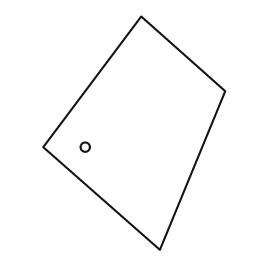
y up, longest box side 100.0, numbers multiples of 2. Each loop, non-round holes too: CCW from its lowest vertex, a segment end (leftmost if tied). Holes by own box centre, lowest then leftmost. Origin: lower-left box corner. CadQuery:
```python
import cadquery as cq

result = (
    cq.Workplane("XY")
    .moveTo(50.0, 0.0)
    .lineTo(78.0, 68.0)
    .lineTo(42.0, 100.0)
    .lineTo(0.0, 44.0)
    .close()
    .moveTo(18.0, 44.0)
    .circle(2.0)
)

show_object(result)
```